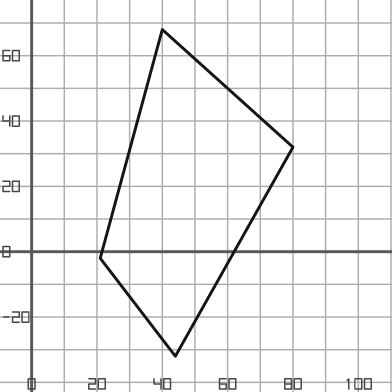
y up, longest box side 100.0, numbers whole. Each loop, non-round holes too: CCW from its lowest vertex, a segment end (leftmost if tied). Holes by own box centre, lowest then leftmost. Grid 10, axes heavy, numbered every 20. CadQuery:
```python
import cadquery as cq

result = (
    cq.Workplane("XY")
    .moveTo(44.0, -32.0)
    .lineTo(80.0, 32.0)
    .lineTo(40.0, 68.0)
    .lineTo(21.0, -2.0)
    .close()
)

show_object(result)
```